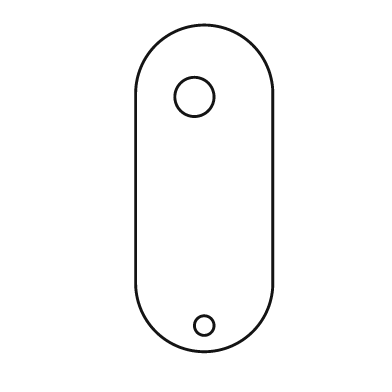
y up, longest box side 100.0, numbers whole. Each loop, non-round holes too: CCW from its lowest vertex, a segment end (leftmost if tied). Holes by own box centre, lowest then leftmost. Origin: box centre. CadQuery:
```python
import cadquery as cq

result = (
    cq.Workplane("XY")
    .moveTo(-21.0, -29.0)
    .threePointArc((0.0, -50.0), (21.0, -29.0))
    .lineTo(21.0, 29.0)
    .threePointArc((0.0, 50.0), (-21.0, 29.0))
    .close()
    .moveTo(0.0, -42.0)
    .circle(3.0)
    .moveTo(-3.0, 28.0)
    .circle(6.0)
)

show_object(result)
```